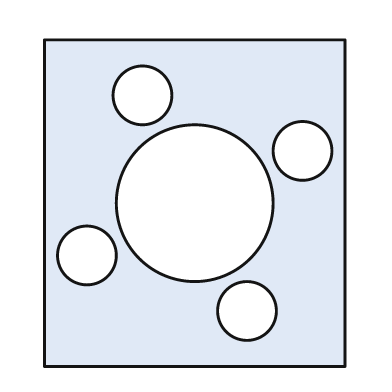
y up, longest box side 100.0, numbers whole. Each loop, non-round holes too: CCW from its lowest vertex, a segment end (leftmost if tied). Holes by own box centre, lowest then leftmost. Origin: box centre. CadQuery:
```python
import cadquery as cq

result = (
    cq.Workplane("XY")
    .moveTo(-46.0, -50.0)
    .lineTo(46.0, -50.0)
    .lineTo(46.0, 50.0)
    .lineTo(-46.0, 50.0)
    .close()
    .moveTo(16.0, -33.0)
    .circle(9.0)
    .moveTo(-33.0, -16.0)
    .circle(9.0)
    .moveTo(0.0, 0.0)
    .circle(24.0)
    .moveTo(33.0, 16.0)
    .circle(9.0)
    .moveTo(-16.0, 33.0)
    .circle(9.0)
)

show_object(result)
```